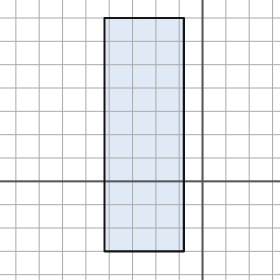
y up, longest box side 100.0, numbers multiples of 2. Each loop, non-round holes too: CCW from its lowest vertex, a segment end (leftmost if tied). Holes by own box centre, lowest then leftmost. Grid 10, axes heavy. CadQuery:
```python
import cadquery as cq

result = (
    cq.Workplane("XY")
    .moveTo(-42.0, -30.0)
    .lineTo(-8.0, -30.0)
    .lineTo(-8.0, 70.0)
    .lineTo(-42.0, 70.0)
    .close()
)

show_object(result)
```